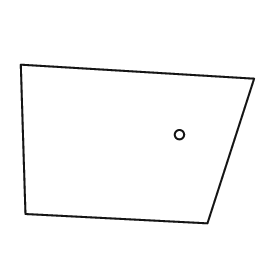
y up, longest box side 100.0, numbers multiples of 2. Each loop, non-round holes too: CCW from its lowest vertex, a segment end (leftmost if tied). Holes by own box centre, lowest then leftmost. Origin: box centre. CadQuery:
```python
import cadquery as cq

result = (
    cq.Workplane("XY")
    .moveTo(30.0, -34.0)
    .lineTo(50.0, 28.0)
    .lineTo(-50.0, 34.0)
    .lineTo(-48.0, -30.0)
    .close()
    .moveTo(18.0, 4.0)
    .circle(2.0)
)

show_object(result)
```